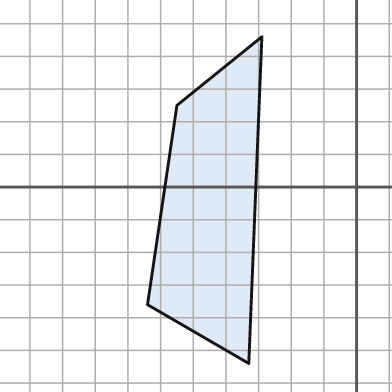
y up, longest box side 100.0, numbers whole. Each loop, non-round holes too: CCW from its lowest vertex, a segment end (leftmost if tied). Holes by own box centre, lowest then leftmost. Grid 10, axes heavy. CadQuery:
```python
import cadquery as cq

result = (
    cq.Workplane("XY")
    .moveTo(-33.0, -54.0)
    .lineTo(-29.0, 46.0)
    .lineTo(-55.0, 25.0)
    .lineTo(-64.0, -36.0)
    .close()
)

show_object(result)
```